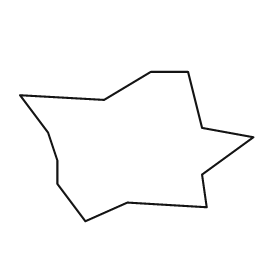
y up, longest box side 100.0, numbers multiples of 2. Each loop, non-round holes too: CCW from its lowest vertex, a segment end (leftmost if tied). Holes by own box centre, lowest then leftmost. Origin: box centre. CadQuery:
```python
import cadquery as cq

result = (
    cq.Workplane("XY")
    .moveTo(-22.0, -32.0)
    .lineTo(-4.0, -24.0)
    .lineTo(30.0, -26.0)
    .lineTo(28.0, -12.0)
    .lineTo(50.0, 4.0)
    .lineTo(28.0, 8.0)
    .lineTo(22.0, 32.0)
    .lineTo(6.0, 32.0)
    .lineTo(-14.0, 20.0)
    .lineTo(-50.0, 22.0)
    .lineTo(-38.0, 6.0)
    .lineTo(-34.0, -6.0)
    .lineTo(-34.0, -16.0)
    .close()
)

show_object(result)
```